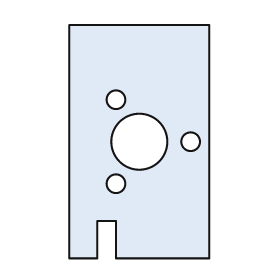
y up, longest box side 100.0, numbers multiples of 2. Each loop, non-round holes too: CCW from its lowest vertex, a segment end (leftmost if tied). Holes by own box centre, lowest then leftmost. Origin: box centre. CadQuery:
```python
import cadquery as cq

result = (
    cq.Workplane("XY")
    .moveTo(-30.0, -50.0)
    .lineTo(-18.0, -50.0)
    .lineTo(-18.0, -34.0)
    .lineTo(-10.0, -34.0)
    .lineTo(-10.0, -50.0)
    .lineTo(30.0, -50.0)
    .lineTo(30.0, 50.0)
    .lineTo(-30.0, 50.0)
    .close()
    .moveTo(-10.0, -18.0)
    .circle(4.0)
    .moveTo(0.0, 0.0)
    .circle(12.0)
    .moveTo(22.0, 0.0)
    .circle(4.0)
    .moveTo(-10.0, 18.0)
    .circle(4.0)
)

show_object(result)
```